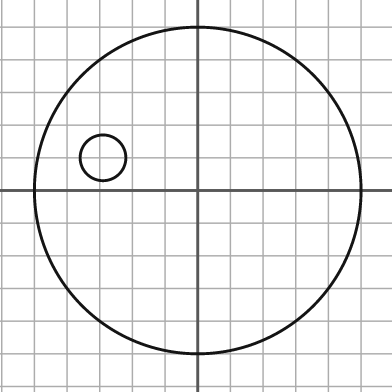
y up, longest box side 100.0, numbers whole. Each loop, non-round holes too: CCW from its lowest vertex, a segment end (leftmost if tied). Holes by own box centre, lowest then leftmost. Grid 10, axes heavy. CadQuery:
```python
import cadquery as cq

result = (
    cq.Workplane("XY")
    .moveTo(0.0, 0.0)
    .circle(50.0)
    .moveTo(-29.0, 10.0)
    .circle(7.0)
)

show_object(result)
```